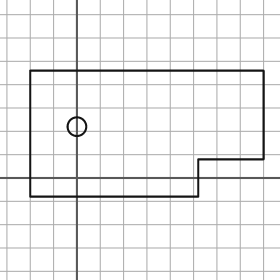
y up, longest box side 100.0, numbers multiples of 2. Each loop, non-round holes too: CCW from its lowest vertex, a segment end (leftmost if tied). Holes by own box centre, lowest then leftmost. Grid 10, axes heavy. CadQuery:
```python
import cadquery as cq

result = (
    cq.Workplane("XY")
    .moveTo(-20.0, -8.0)
    .lineTo(52.0, -8.0)
    .lineTo(52.0, 8.0)
    .lineTo(80.0, 8.0)
    .lineTo(80.0, 46.0)
    .lineTo(-20.0, 46.0)
    .close()
    .moveTo(0.0, 22.0)
    .circle(4.0)
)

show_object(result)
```